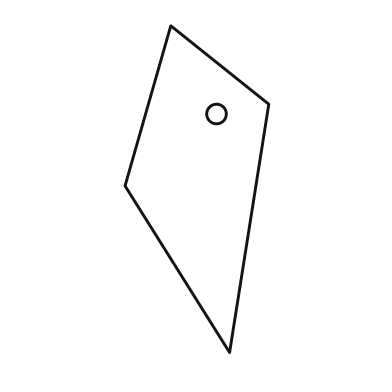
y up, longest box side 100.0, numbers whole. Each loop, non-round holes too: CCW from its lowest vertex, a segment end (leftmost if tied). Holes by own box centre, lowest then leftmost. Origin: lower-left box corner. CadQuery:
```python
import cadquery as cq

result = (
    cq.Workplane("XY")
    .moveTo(32.0, 0.0)
    .lineTo(44.0, 76.0)
    .lineTo(14.0, 100.0)
    .lineTo(0.0, 51.0)
    .close()
    .moveTo(28.0, 73.0)
    .circle(3.0)
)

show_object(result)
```